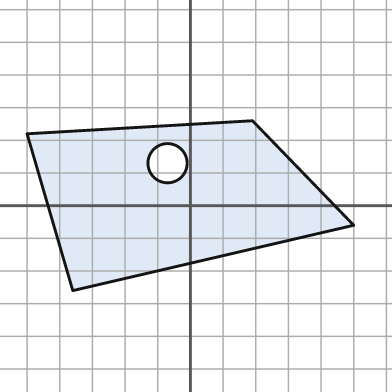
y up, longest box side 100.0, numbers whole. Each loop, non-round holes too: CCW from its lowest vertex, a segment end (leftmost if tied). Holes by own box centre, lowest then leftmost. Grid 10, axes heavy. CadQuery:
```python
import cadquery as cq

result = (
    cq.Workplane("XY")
    .moveTo(-36.0, -26.0)
    .lineTo(50.0, -6.0)
    .lineTo(19.0, 26.0)
    .lineTo(-50.0, 22.0)
    .close()
    .moveTo(-7.0, 13.0)
    .circle(6.0)
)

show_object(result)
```